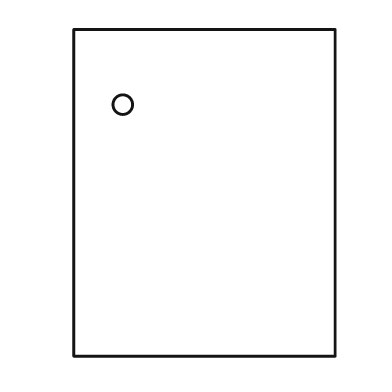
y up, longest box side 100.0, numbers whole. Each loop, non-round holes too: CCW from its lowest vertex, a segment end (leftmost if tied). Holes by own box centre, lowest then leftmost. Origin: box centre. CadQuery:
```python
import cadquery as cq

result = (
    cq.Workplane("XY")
    .moveTo(-40.0, -50.0)
    .lineTo(40.0, -50.0)
    .lineTo(40.0, 50.0)
    .lineTo(-40.0, 50.0)
    .close()
    .moveTo(-25.0, 27.0)
    .circle(3.0)
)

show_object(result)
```